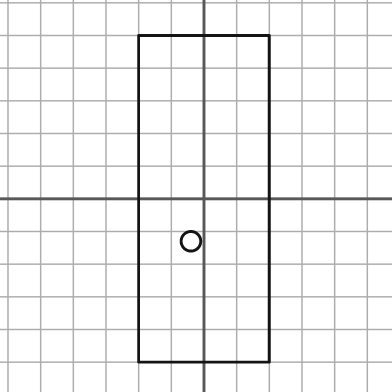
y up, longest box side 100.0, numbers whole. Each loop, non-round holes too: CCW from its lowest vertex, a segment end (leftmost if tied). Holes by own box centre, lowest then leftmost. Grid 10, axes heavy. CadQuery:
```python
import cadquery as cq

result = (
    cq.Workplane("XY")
    .moveTo(-20.0, -50.0)
    .lineTo(20.0, -50.0)
    .lineTo(20.0, 50.0)
    .lineTo(-20.0, 50.0)
    .close()
    .moveTo(-4.0, -13.0)
    .circle(3.0)
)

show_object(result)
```